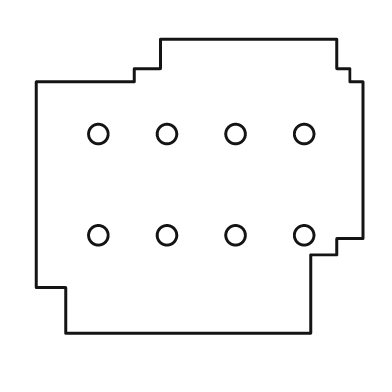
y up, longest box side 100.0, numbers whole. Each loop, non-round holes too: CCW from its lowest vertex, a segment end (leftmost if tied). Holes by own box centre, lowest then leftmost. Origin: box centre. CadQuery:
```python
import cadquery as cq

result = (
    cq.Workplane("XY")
    .moveTo(-41.0, -45.0)
    .lineTo(34.0, -45.0)
    .lineTo(34.0, -21.0)
    .lineTo(42.0, -21.0)
    .lineTo(42.0, -16.0)
    .lineTo(50.0, -16.0)
    .lineTo(50.0, 32.0)
    .lineTo(46.0, 32.0)
    .lineTo(46.0, 36.0)
    .lineTo(42.0, 36.0)
    .lineTo(42.0, 45.0)
    .lineTo(-12.0, 45.0)
    .lineTo(-12.0, 36.0)
    .lineTo(-20.0, 36.0)
    .lineTo(-20.0, 32.0)
    .lineTo(-50.0, 32.0)
    .lineTo(-50.0, -31.0)
    .lineTo(-41.0, -31.0)
    .close()
    .moveTo(-31.0, -15.0)
    .circle(3.0)
    .moveTo(-10.0, -15.0)
    .circle(3.0)
    .moveTo(11.0, -15.0)
    .circle(3.0)
    .moveTo(32.0, -15.0)
    .circle(3.0)
    .moveTo(-31.0, 16.0)
    .circle(3.0)
    .moveTo(-10.0, 16.0)
    .circle(3.0)
    .moveTo(11.0, 16.0)
    .circle(3.0)
    .moveTo(32.0, 16.0)
    .circle(3.0)
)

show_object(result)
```